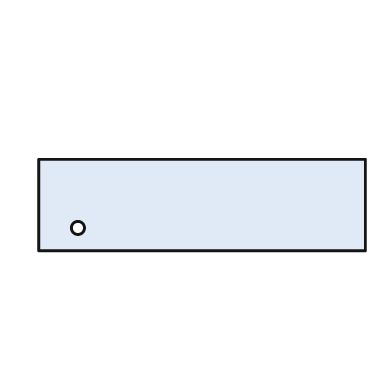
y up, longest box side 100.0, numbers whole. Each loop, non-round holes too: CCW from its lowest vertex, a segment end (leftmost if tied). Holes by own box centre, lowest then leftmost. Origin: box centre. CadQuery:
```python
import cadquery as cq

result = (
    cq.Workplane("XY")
    .moveTo(-50.0, -14.0)
    .lineTo(50.0, -14.0)
    .lineTo(50.0, 14.0)
    .lineTo(-50.0, 14.0)
    .close()
    .moveTo(-38.0, -7.0)
    .circle(2.0)
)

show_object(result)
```